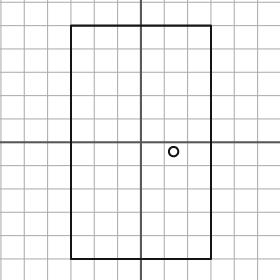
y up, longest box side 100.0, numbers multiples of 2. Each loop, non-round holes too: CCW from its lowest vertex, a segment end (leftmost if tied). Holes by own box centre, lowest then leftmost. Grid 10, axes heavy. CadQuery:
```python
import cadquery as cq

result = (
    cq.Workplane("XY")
    .moveTo(-30.0, -50.0)
    .lineTo(30.0, -50.0)
    .lineTo(30.0, 50.0)
    .lineTo(-30.0, 50.0)
    .close()
    .moveTo(14.0, -4.0)
    .circle(2.0)
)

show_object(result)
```